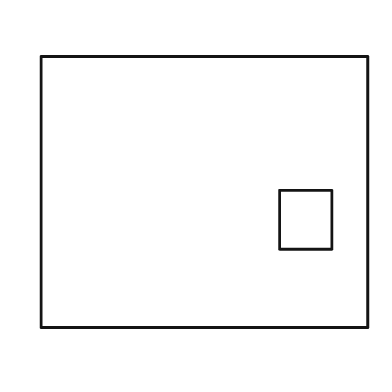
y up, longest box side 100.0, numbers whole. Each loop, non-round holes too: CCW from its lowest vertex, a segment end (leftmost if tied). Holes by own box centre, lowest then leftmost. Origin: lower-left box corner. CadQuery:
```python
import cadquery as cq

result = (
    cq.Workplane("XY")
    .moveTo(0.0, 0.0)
    .lineTo(100.0, 0.0)
    .lineTo(100.0, 83.0)
    .lineTo(0.0, 83.0)
    .close()
    .moveTo(73.0, 24.0)
    .lineTo(89.0, 24.0)
    .lineTo(89.0, 42.0)
    .lineTo(73.0, 42.0)
    .close()
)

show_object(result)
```